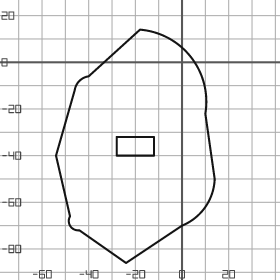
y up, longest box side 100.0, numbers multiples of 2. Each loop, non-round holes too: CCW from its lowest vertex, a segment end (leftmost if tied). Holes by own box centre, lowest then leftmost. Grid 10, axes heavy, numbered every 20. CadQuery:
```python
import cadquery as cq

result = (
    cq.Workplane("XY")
    .moveTo(-24.0, -86.0)
    .lineTo(0.0, -70.0)
    .threePointArc((10.0, -62.0), (14.0, -50.0))
    .lineTo(10.0, -22.0)
    .threePointArc((4.0, 2.0), (-18.0, 14.0))
    .lineTo(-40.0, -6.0)
    .threePointArc((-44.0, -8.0), (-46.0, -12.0))
    .lineTo(-54.0, -40.0)
    .lineTo(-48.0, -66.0)
    .threePointArc((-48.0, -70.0), (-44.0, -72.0))
    .close()
    .moveTo(-28.0, -40.0)
    .lineTo(-12.0, -40.0)
    .lineTo(-12.0, -32.0)
    .lineTo(-28.0, -32.0)
    .close()
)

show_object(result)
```